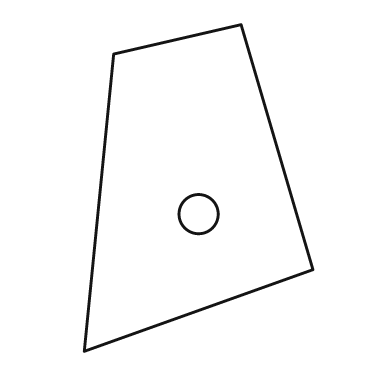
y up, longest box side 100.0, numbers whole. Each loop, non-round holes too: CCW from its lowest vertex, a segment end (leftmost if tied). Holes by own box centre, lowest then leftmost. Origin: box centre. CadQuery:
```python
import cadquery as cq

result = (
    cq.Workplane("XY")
    .moveTo(-35.0, -50.0)
    .lineTo(35.0, -25.0)
    .lineTo(13.0, 50.0)
    .lineTo(-26.0, 41.0)
    .close()
    .moveTo(0.0, -8.0)
    .circle(6.0)
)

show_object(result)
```